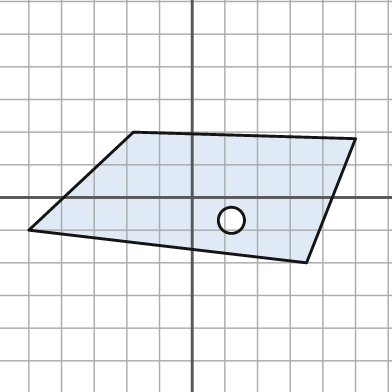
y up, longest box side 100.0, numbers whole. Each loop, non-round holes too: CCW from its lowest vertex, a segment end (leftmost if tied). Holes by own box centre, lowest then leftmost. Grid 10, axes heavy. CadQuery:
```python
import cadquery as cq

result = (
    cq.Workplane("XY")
    .moveTo(35.0, -20.0)
    .lineTo(50.0, 18.0)
    .lineTo(-18.0, 20.0)
    .lineTo(-50.0, -10.0)
    .close()
    .moveTo(12.0, -7.0)
    .circle(4.0)
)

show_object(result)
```